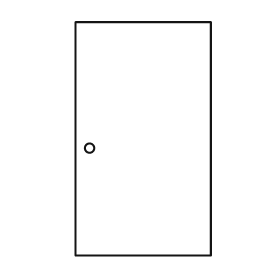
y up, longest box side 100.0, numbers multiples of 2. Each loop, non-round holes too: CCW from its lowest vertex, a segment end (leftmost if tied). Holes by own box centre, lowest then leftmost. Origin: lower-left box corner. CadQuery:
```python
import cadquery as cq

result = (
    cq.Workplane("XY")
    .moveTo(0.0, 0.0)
    .lineTo(58.0, 0.0)
    .lineTo(58.0, 100.0)
    .lineTo(0.0, 100.0)
    .close()
    .moveTo(6.0, 46.0)
    .circle(2.0)
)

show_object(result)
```